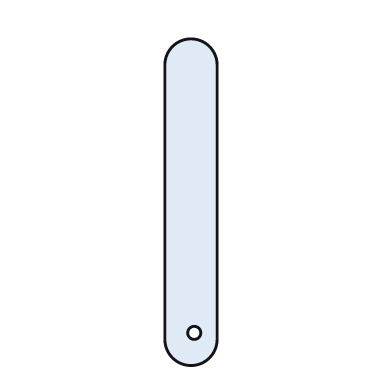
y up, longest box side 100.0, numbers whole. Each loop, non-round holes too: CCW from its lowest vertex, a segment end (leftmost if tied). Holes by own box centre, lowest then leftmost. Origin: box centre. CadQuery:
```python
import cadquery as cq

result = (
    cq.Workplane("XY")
    .moveTo(-8.0, -42.0)
    .threePointArc((0.0, -50.0), (8.0, -42.0))
    .lineTo(8.0, 42.0)
    .threePointArc((0.0, 50.0), (-8.0, 42.0))
    .close()
    .moveTo(1.0, -40.0)
    .circle(2.0)
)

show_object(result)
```